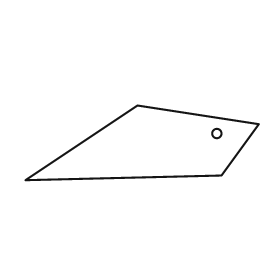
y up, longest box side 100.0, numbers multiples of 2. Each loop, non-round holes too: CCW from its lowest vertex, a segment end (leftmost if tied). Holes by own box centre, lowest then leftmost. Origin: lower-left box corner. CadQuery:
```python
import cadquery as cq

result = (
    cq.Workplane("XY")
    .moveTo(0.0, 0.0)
    .lineTo(84.0, 2.0)
    .lineTo(100.0, 24.0)
    .lineTo(48.0, 32.0)
    .close()
    .moveTo(82.0, 20.0)
    .circle(2.0)
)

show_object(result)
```